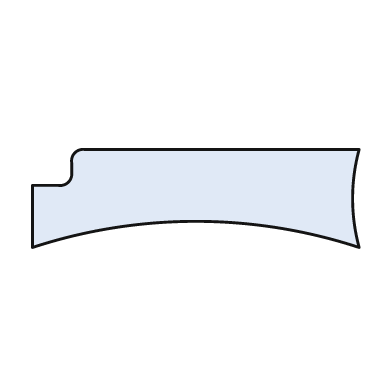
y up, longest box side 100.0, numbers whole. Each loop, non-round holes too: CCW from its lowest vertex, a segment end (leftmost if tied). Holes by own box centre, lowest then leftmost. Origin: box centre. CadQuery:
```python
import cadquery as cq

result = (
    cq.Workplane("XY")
    .moveTo(-50.0, -15.0)
    .threePointArc((0.0, -7.0), (50.0, -15.0))
    .threePointArc((48.0, 0.0), (50.0, 15.0))
    .lineTo(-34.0, 15.0)
    .threePointArc((-37.0, 14.0), (-38.0, 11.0))
    .lineTo(-38.0, 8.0)
    .threePointArc((-39.0, 5.0), (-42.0, 4.0))
    .lineTo(-50.0, 4.0)
    .close()
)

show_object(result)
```